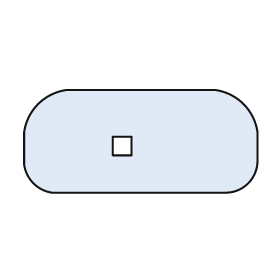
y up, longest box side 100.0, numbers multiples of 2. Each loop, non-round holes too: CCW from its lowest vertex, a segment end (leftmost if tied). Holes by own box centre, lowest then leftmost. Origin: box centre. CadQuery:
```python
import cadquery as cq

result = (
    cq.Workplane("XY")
    .moveTo(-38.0, -22.0)
    .lineTo(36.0, -22.0)
    .threePointArc((46.0, -18.0), (50.0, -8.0))
    .lineTo(50.0, 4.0)
    .threePointArc((44.0, 16.0), (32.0, 22.0))
    .lineTo(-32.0, 22.0)
    .threePointArc((-44.0, 16.0), (-50.0, 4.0))
    .lineTo(-50.0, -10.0)
    .threePointArc((-46.0, -18.0), (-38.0, -22.0))
    .close()
    .moveTo(-12.0, -6.0)
    .lineTo(-4.0, -6.0)
    .lineTo(-4.0, 2.0)
    .lineTo(-12.0, 2.0)
    .close()
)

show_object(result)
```